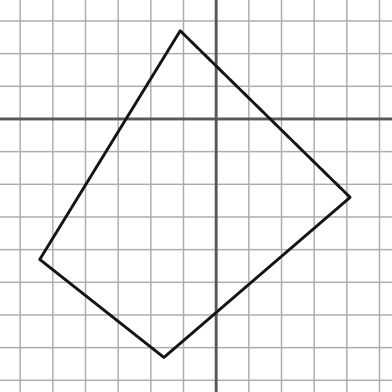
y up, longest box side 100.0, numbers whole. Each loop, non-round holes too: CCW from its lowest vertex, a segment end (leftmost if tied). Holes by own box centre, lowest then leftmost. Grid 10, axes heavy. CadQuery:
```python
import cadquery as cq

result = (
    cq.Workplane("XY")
    .moveTo(-16.0, -73.0)
    .lineTo(41.0, -24.0)
    .lineTo(-11.0, 27.0)
    .lineTo(-54.0, -43.0)
    .close()
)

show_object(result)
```